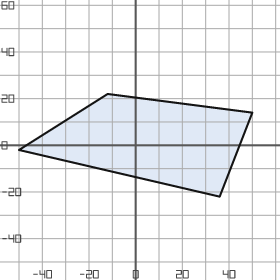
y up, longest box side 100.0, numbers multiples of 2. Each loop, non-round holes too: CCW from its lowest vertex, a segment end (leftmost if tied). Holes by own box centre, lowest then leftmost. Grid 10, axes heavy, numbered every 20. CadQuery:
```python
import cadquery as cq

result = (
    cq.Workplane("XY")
    .moveTo(36.0, -22.0)
    .lineTo(50.0, 14.0)
    .lineTo(-12.0, 22.0)
    .lineTo(-50.0, -2.0)
    .close()
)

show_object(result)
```